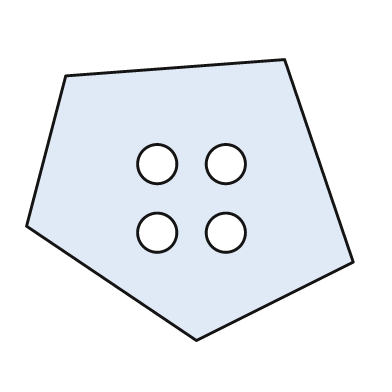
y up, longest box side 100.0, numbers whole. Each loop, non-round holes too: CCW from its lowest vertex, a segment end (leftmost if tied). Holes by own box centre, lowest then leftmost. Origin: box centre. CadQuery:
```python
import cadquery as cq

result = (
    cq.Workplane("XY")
    .moveTo(2.0, -43.0)
    .lineTo(50.0, -19.0)
    .lineTo(29.0, 43.0)
    .lineTo(-38.0, 38.0)
    .lineTo(-50.0, -8.0)
    .close()
    .moveTo(-10.0, -10.0)
    .circle(6.0)
    .moveTo(11.0, -10.0)
    .circle(6.0)
    .moveTo(-10.0, 11.0)
    .circle(6.0)
    .moveTo(11.0, 11.0)
    .circle(6.0)
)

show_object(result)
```